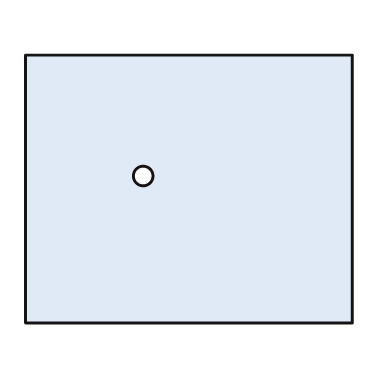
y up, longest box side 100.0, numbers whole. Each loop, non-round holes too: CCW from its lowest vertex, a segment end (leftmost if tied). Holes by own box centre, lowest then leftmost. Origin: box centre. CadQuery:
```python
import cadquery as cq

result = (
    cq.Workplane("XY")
    .moveTo(-50.0, -41.0)
    .lineTo(50.0, -41.0)
    .lineTo(50.0, 41.0)
    .lineTo(-50.0, 41.0)
    .close()
    .moveTo(-14.0, 4.0)
    .circle(3.0)
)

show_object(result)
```